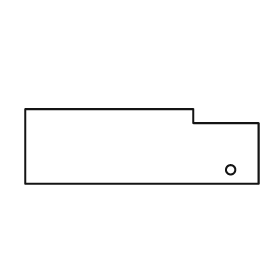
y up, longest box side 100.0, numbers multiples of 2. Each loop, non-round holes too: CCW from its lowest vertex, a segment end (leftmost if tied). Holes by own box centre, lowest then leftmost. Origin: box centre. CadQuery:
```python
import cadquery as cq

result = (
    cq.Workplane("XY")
    .moveTo(-50.0, -16.0)
    .lineTo(50.0, -16.0)
    .lineTo(50.0, 10.0)
    .lineTo(22.0, 10.0)
    .lineTo(22.0, 16.0)
    .lineTo(-50.0, 16.0)
    .close()
    .moveTo(38.0, -10.0)
    .circle(2.0)
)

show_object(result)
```